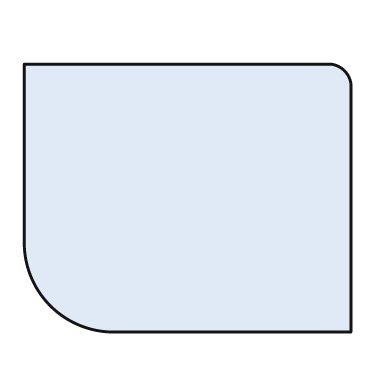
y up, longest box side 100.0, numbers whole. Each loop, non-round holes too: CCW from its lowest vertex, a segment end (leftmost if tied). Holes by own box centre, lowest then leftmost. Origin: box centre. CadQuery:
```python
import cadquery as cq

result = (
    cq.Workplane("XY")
    .moveTo(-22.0, -41.0)
    .lineTo(50.0, -41.0)
    .lineTo(50.0, 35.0)
    .threePointArc((48.0, 39.0), (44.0, 41.0))
    .lineTo(-50.0, 41.0)
    .lineTo(-50.0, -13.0)
    .threePointArc((-42.0, -33.0), (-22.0, -41.0))
    .close()
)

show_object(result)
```